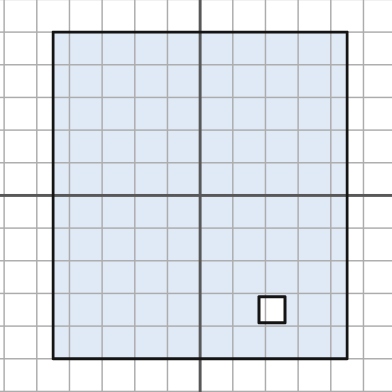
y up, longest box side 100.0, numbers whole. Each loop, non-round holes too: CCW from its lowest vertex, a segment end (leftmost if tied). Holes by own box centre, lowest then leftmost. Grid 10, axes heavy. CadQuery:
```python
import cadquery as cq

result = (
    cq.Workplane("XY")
    .moveTo(-45.0, -50.0)
    .lineTo(45.0, -50.0)
    .lineTo(45.0, 50.0)
    .lineTo(-45.0, 50.0)
    .close()
    .moveTo(18.0, -39.0)
    .lineTo(26.0, -39.0)
    .lineTo(26.0, -31.0)
    .lineTo(18.0, -31.0)
    .close()
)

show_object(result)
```